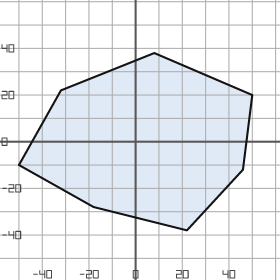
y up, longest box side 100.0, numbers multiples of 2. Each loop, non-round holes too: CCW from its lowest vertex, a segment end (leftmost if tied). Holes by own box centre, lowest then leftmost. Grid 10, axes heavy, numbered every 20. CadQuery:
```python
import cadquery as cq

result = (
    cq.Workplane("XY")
    .moveTo(22.0, -38.0)
    .lineTo(46.0, -12.0)
    .lineTo(50.0, 20.0)
    .lineTo(8.0, 38.0)
    .lineTo(-32.0, 22.0)
    .lineTo(-50.0, -10.0)
    .lineTo(-18.0, -28.0)
    .close()
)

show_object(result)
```